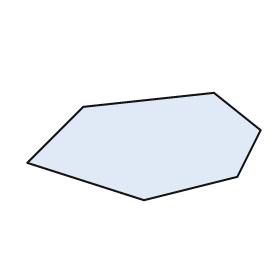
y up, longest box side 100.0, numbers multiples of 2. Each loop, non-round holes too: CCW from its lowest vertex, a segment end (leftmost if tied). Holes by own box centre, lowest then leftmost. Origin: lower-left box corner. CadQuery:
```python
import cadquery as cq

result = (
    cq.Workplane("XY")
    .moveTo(50.0, 0.0)
    .lineTo(90.0, 10.0)
    .lineTo(100.0, 30.0)
    .lineTo(80.0, 46.0)
    .lineTo(24.0, 40.0)
    .lineTo(0.0, 16.0)
    .close()
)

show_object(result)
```